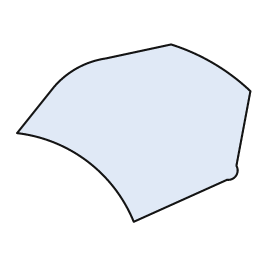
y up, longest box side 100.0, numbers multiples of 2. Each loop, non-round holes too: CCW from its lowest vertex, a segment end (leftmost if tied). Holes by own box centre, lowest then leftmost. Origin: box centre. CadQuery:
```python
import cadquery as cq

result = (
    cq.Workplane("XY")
    .moveTo(0.0, -38.0)
    .lineTo(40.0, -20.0)
    .threePointArc((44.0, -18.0), (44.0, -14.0))
    .lineTo(50.0, 18.0)
    .threePointArc((34.0, 30.0), (16.0, 38.0))
    .lineTo(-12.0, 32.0)
    .threePointArc((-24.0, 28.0), (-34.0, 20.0))
    .lineTo(-50.0, 0.0)
    .threePointArc((-20.0, -12.0), (0.0, -38.0))
    .close()
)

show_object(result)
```